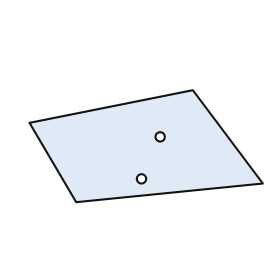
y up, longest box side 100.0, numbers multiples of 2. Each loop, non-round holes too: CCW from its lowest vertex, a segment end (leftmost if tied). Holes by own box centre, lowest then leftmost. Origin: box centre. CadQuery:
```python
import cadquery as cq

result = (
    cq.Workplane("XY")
    .moveTo(-30.0, -24.0)
    .lineTo(50.0, -16.0)
    .lineTo(20.0, 24.0)
    .lineTo(-50.0, 10.0)
    .close()
    .moveTo(-2.0, -14.0)
    .circle(2.0)
    .moveTo(6.0, 4.0)
    .circle(2.0)
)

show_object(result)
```